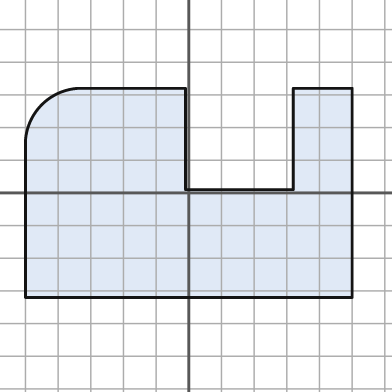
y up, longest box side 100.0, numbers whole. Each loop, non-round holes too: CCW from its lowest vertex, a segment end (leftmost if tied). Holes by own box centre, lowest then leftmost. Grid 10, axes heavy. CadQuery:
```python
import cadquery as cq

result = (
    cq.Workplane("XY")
    .moveTo(-50.0, -32.0)
    .lineTo(50.0, -32.0)
    .lineTo(50.0, 32.0)
    .lineTo(32.0, 32.0)
    .lineTo(32.0, 1.0)
    .lineTo(-1.0, 1.0)
    .lineTo(-1.0, 32.0)
    .lineTo(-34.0, 32.0)
    .threePointArc((-45.0, 27.0), (-50.0, 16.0))
    .close()
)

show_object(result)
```